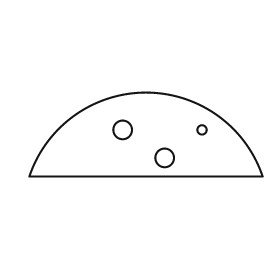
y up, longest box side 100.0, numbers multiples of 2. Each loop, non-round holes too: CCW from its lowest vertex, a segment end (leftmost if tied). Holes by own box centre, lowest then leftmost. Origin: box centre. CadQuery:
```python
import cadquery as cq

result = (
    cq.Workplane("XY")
    .moveTo(-50.0, -18.0)
    .lineTo(50.0, -18.0)
    .threePointArc((0.0, 18.0), (-50.0, -18.0))
    .close()
    .moveTo(8.0, -10.0)
    .circle(4.0)
    .moveTo(-10.0, 2.0)
    .circle(4.0)
    .moveTo(24.0, 2.0)
    .circle(2.0)
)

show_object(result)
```